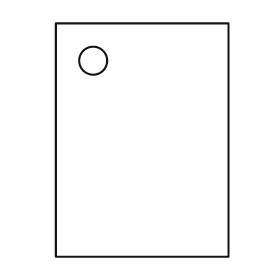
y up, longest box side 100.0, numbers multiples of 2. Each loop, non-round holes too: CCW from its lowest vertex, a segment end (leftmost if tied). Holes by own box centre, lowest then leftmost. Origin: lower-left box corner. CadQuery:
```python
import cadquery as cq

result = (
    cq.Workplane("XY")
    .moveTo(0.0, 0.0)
    .lineTo(74.0, 0.0)
    .lineTo(74.0, 100.0)
    .lineTo(0.0, 100.0)
    .close()
    .moveTo(16.0, 84.0)
    .circle(6.0)
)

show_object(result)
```